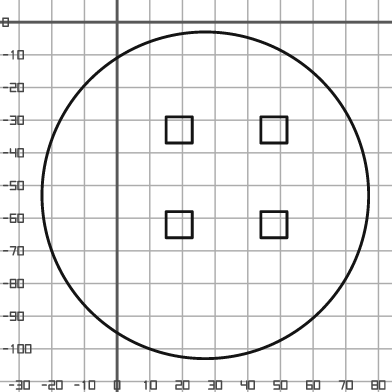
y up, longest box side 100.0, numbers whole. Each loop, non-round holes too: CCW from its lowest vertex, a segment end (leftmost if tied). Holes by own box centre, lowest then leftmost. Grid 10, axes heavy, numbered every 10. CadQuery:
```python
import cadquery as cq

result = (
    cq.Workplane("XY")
    .moveTo(27.0, -53.0)
    .circle(50.0)
    .moveTo(15.0, -66.0)
    .lineTo(23.0, -66.0)
    .lineTo(23.0, -58.0)
    .lineTo(15.0, -58.0)
    .close()
    .moveTo(44.0, -66.0)
    .lineTo(52.0, -66.0)
    .lineTo(52.0, -58.0)
    .lineTo(44.0, -58.0)
    .close()
    .moveTo(15.0, -37.0)
    .lineTo(23.0, -37.0)
    .lineTo(23.0, -29.0)
    .lineTo(15.0, -29.0)
    .close()
    .moveTo(44.0, -37.0)
    .lineTo(52.0, -37.0)
    .lineTo(52.0, -29.0)
    .lineTo(44.0, -29.0)
    .close()
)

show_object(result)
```